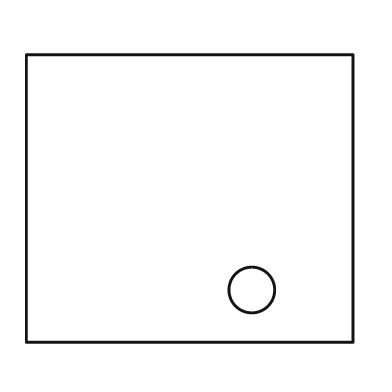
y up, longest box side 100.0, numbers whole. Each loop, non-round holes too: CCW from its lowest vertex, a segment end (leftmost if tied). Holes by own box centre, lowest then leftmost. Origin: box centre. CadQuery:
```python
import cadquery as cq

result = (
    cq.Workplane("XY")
    .moveTo(-50.0, -44.0)
    .lineTo(50.0, -44.0)
    .lineTo(50.0, 44.0)
    .lineTo(-50.0, 44.0)
    .close()
    .moveTo(19.0, -28.0)
    .circle(7.0)
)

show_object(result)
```